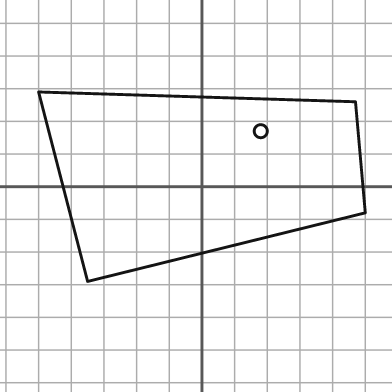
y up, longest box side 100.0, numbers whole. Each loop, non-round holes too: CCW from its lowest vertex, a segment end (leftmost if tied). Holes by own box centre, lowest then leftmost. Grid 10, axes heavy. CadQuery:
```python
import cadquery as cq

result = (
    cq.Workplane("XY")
    .moveTo(-35.0, -29.0)
    .lineTo(50.0, -8.0)
    .lineTo(47.0, 26.0)
    .lineTo(-50.0, 29.0)
    .close()
    .moveTo(18.0, 17.0)
    .circle(2.0)
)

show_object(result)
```